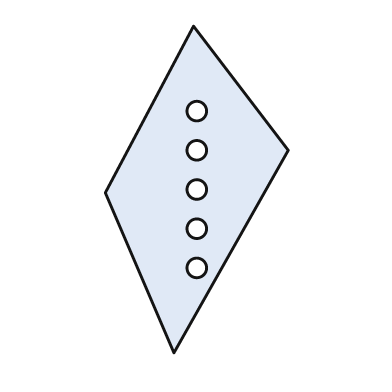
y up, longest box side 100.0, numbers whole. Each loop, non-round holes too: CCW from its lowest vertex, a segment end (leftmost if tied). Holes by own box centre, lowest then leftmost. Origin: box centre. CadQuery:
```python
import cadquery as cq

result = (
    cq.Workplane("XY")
    .moveTo(-7.0, -50.0)
    .lineTo(28.0, 12.0)
    .lineTo(-1.0, 50.0)
    .lineTo(-28.0, -1.0)
    .close()
    .moveTo(0.0, -24.0)
    .circle(3.0)
    .moveTo(0.0, -12.0)
    .circle(3.0)
    .moveTo(0.0, 0.0)
    .circle(3.0)
    .moveTo(0.0, 12.0)
    .circle(3.0)
    .moveTo(0.0, 24.0)
    .circle(3.0)
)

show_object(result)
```